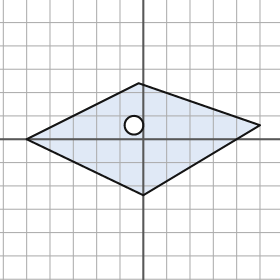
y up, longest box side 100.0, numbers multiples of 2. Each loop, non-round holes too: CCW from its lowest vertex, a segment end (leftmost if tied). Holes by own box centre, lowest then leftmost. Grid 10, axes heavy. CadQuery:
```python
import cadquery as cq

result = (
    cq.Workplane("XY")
    .moveTo(0.0, -24.0)
    .lineTo(50.0, 6.0)
    .lineTo(-2.0, 24.0)
    .lineTo(-50.0, 0.0)
    .close()
    .moveTo(-4.0, 6.0)
    .circle(4.0)
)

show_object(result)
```